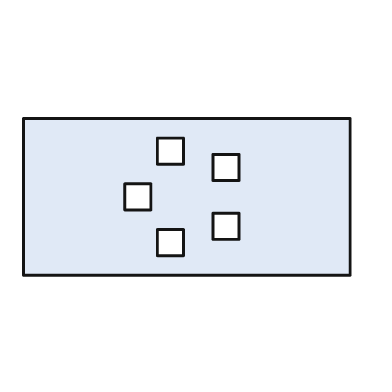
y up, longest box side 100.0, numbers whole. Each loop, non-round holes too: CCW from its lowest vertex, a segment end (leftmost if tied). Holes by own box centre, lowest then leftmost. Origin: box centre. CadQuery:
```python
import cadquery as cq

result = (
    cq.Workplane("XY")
    .moveTo(-50.0, -24.0)
    .lineTo(50.0, -24.0)
    .lineTo(50.0, 24.0)
    .lineTo(-50.0, 24.0)
    .close()
    .moveTo(-9.0, -18.0)
    .lineTo(-1.0, -18.0)
    .lineTo(-1.0, -10.0)
    .lineTo(-9.0, -10.0)
    .close()
    .moveTo(8.0, -13.0)
    .lineTo(16.0, -13.0)
    .lineTo(16.0, -5.0)
    .lineTo(8.0, -5.0)
    .close()
    .moveTo(-19.0, -4.0)
    .lineTo(-11.0, -4.0)
    .lineTo(-11.0, 4.0)
    .lineTo(-19.0, 4.0)
    .close()
    .moveTo(8.0, 5.0)
    .lineTo(16.0, 5.0)
    .lineTo(16.0, 13.0)
    .lineTo(8.0, 13.0)
    .close()
    .moveTo(-9.0, 10.0)
    .lineTo(-1.0, 10.0)
    .lineTo(-1.0, 18.0)
    .lineTo(-9.0, 18.0)
    .close()
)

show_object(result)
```